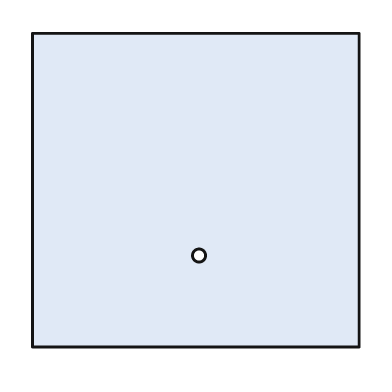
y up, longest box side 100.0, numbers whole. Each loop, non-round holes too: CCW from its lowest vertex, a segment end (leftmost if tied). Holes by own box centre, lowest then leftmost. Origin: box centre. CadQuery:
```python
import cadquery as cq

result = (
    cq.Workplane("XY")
    .moveTo(-50.0, -48.0)
    .lineTo(50.0, -48.0)
    .lineTo(50.0, 48.0)
    .lineTo(-50.0, 48.0)
    .close()
    .moveTo(1.0, -20.0)
    .circle(2.0)
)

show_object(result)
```